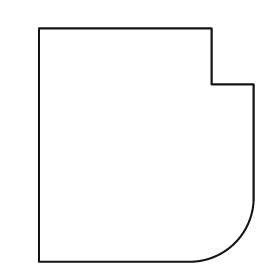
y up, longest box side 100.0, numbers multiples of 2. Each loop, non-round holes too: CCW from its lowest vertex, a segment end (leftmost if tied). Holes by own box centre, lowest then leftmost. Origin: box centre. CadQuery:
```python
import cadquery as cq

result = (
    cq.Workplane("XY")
    .moveTo(-46.0, -50.0)
    .lineTo(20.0, -50.0)
    .threePointArc((38.0, -42.0), (46.0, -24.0))
    .lineTo(46.0, 26.0)
    .lineTo(28.0, 26.0)
    .lineTo(28.0, 50.0)
    .lineTo(-46.0, 50.0)
    .close()
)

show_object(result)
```